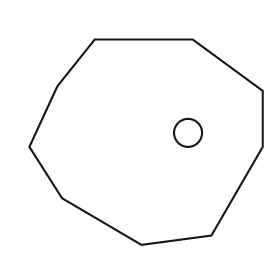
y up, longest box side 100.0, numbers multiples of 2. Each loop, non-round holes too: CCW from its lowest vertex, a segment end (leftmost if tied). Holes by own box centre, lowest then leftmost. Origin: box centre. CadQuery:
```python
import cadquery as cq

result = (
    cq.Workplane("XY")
    .moveTo(-2.0, -44.0)
    .lineTo(28.0, -40.0)
    .lineTo(50.0, -2.0)
    .lineTo(50.0, 22.0)
    .lineTo(20.0, 44.0)
    .lineTo(-22.0, 44.0)
    .lineTo(-38.0, 24.0)
    .lineTo(-50.0, -2.0)
    .lineTo(-36.0, -24.0)
    .close()
    .moveTo(18.0, 4.0)
    .circle(6.0)
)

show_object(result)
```